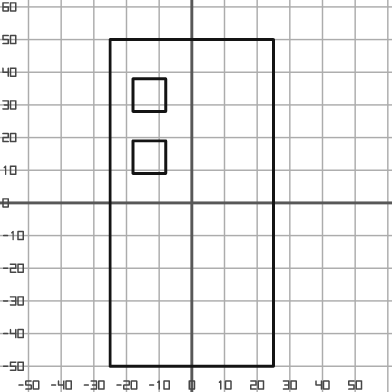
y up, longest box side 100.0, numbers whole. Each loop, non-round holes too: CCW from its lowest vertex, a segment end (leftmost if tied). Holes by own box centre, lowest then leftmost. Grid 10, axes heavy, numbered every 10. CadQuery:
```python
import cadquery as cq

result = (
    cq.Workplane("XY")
    .moveTo(-25.0, -50.0)
    .lineTo(25.0, -50.0)
    .lineTo(25.0, 50.0)
    .lineTo(-25.0, 50.0)
    .close()
    .moveTo(-18.0, 9.0)
    .lineTo(-8.0, 9.0)
    .lineTo(-8.0, 19.0)
    .lineTo(-18.0, 19.0)
    .close()
    .moveTo(-18.0, 28.0)
    .lineTo(-8.0, 28.0)
    .lineTo(-8.0, 38.0)
    .lineTo(-18.0, 38.0)
    .close()
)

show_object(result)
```